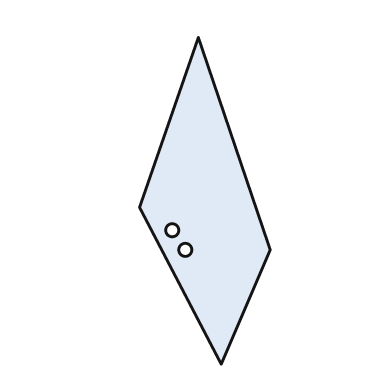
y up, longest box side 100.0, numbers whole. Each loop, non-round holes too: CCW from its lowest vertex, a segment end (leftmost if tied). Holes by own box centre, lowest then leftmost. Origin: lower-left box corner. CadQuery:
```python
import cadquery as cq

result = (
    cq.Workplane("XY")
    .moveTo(25.0, 0.0)
    .lineTo(40.0, 35.0)
    .lineTo(18.0, 100.0)
    .lineTo(0.0, 48.0)
    .close()
    .moveTo(14.0, 35.0)
    .circle(2.0)
    .moveTo(10.0, 41.0)
    .circle(2.0)
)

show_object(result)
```